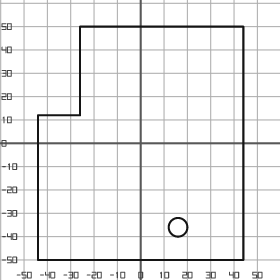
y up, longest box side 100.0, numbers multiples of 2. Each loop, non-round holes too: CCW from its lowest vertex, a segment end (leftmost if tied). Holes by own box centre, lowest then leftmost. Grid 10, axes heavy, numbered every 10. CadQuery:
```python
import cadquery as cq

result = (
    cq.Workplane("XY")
    .moveTo(-44.0, -50.0)
    .lineTo(44.0, -50.0)
    .lineTo(44.0, 50.0)
    .lineTo(-26.0, 50.0)
    .lineTo(-26.0, 12.0)
    .lineTo(-44.0, 12.0)
    .close()
    .moveTo(16.0, -36.0)
    .circle(4.0)
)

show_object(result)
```